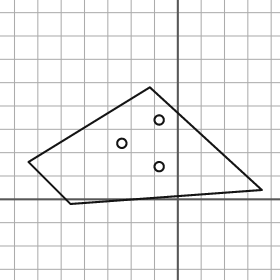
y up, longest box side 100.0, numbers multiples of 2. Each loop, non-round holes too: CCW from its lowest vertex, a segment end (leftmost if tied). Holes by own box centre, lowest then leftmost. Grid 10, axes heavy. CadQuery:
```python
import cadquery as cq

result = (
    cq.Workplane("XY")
    .moveTo(-46.0, -2.0)
    .lineTo(36.0, 4.0)
    .lineTo(-12.0, 48.0)
    .lineTo(-64.0, 16.0)
    .close()
    .moveTo(-8.0, 14.0)
    .circle(2.0)
    .moveTo(-24.0, 24.0)
    .circle(2.0)
    .moveTo(-8.0, 34.0)
    .circle(2.0)
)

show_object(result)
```